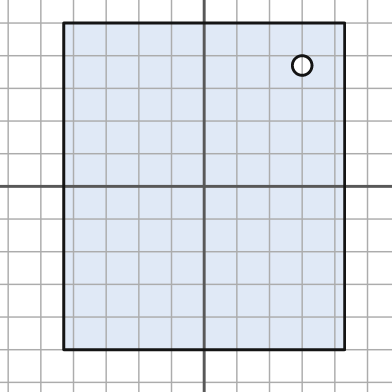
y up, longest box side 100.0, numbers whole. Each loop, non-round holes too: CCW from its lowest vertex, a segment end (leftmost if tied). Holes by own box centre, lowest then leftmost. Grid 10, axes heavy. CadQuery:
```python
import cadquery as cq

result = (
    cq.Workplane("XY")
    .moveTo(-43.0, -50.0)
    .lineTo(43.0, -50.0)
    .lineTo(43.0, 50.0)
    .lineTo(-43.0, 50.0)
    .close()
    .moveTo(30.0, 37.0)
    .circle(3.0)
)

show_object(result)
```